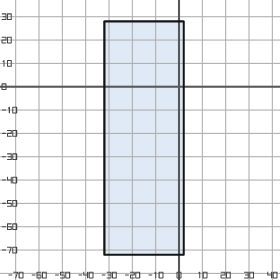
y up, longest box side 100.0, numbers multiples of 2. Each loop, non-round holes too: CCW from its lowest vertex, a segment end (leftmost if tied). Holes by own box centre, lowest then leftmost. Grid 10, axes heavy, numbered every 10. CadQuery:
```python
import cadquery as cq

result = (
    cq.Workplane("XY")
    .moveTo(-32.0, -72.0)
    .lineTo(2.0, -72.0)
    .lineTo(2.0, 28.0)
    .lineTo(-32.0, 28.0)
    .close()
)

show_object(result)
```